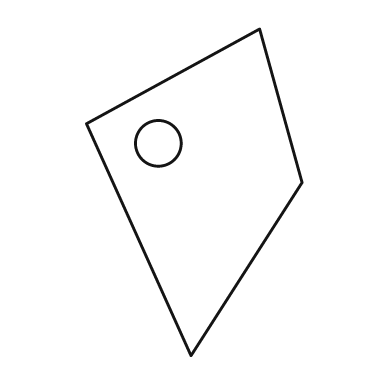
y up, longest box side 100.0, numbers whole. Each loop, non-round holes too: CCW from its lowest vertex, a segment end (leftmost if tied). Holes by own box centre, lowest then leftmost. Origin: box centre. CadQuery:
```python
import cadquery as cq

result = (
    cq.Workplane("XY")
    .moveTo(-1.0, -50.0)
    .lineTo(33.0, 3.0)
    .lineTo(20.0, 50.0)
    .lineTo(-33.0, 21.0)
    .close()
    .moveTo(-11.0, 15.0)
    .circle(7.0)
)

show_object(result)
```